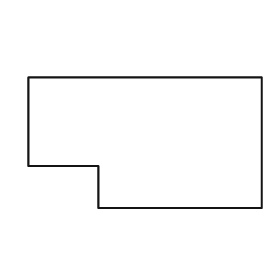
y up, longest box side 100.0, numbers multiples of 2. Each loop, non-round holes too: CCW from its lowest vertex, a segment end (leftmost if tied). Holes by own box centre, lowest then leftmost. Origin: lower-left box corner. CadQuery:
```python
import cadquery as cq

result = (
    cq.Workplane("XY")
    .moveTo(30.0, 0.0)
    .lineTo(100.0, 0.0)
    .lineTo(100.0, 56.0)
    .lineTo(0.0, 56.0)
    .lineTo(0.0, 18.0)
    .lineTo(30.0, 18.0)
    .close()
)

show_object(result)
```